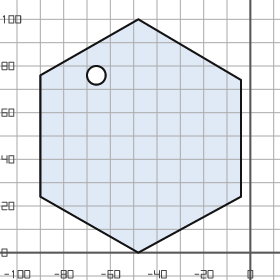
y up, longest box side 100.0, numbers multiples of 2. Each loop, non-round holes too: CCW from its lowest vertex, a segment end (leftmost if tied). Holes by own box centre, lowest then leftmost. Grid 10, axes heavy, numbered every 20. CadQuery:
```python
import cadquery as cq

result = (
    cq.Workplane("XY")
    .moveTo(-48.0, 0.0)
    .lineTo(-4.0, 24.0)
    .lineTo(-4.0, 74.0)
    .lineTo(-48.0, 100.0)
    .lineTo(-90.0, 76.0)
    .lineTo(-90.0, 24.0)
    .close()
    .moveTo(-66.0, 76.0)
    .circle(4.0)
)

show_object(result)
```